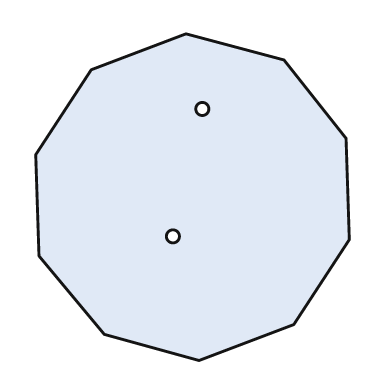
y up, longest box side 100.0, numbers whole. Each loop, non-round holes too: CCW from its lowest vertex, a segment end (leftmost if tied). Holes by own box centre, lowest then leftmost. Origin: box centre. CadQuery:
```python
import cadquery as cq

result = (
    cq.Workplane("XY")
    .moveTo(2.0, -50.0)
    .lineTo(31.0, -39.0)
    .lineTo(48.0, -13.0)
    .lineTo(47.0, 18.0)
    .lineTo(28.0, 42.0)
    .lineTo(-2.0, 50.0)
    .lineTo(-31.0, 39.0)
    .lineTo(-48.0, 13.0)
    .lineTo(-47.0, -18.0)
    .lineTo(-27.0, -42.0)
    .close()
    .moveTo(-6.0, -12.0)
    .circle(2.0)
    .moveTo(3.0, 27.0)
    .circle(2.0)
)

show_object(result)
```